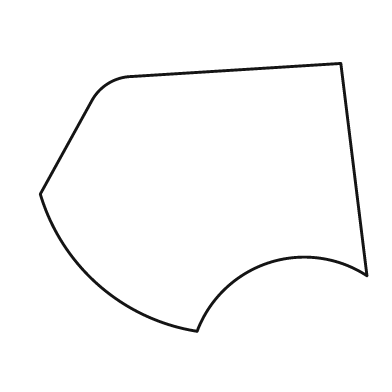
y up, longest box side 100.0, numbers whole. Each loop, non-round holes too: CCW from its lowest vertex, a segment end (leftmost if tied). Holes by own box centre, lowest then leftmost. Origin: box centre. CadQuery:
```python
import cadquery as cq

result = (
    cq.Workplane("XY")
    .moveTo(-2.0, -41.0)
    .threePointArc((20.0, -20.0), (50.0, -24.0))
    .lineTo(42.0, 41.0)
    .lineTo(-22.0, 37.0)
    .threePointArc((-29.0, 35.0), (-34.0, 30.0))
    .lineTo(-50.0, 1.0)
    .threePointArc((-32.0, -27.0), (-2.0, -41.0))
    .close()
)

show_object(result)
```